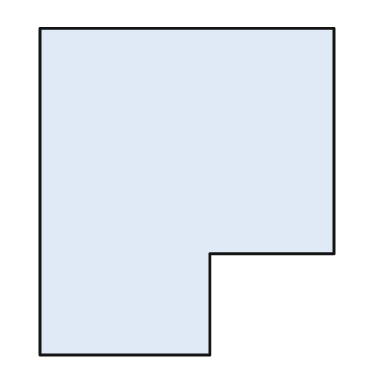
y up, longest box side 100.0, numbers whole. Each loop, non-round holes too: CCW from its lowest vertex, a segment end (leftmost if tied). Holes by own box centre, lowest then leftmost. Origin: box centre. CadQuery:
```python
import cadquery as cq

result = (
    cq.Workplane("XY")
    .moveTo(-45.0, -50.0)
    .lineTo(7.0, -50.0)
    .lineTo(7.0, -19.0)
    .lineTo(45.0, -19.0)
    .lineTo(45.0, 50.0)
    .lineTo(-45.0, 50.0)
    .close()
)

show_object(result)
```